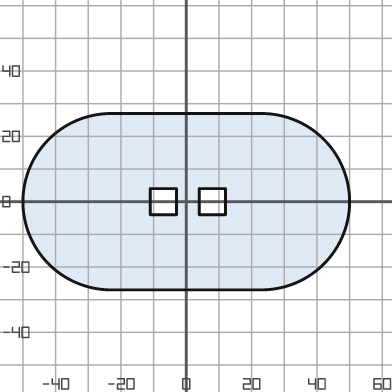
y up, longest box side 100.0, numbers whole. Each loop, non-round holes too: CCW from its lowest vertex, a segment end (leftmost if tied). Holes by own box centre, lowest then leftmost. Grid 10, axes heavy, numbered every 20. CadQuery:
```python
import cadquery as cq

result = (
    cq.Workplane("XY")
    .moveTo(-23.0, -27.0)
    .lineTo(23.0, -27.0)
    .threePointArc((50.0, 0.0), (23.0, 27.0))
    .lineTo(-23.0, 27.0)
    .threePointArc((-50.0, 0.0), (-23.0, -27.0))
    .close()
    .moveTo(-11.0, -4.0)
    .lineTo(-3.0, -4.0)
    .lineTo(-3.0, 4.0)
    .lineTo(-11.0, 4.0)
    .close()
    .moveTo(4.0, -4.0)
    .lineTo(12.0, -4.0)
    .lineTo(12.0, 4.0)
    .lineTo(4.0, 4.0)
    .close()
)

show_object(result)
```